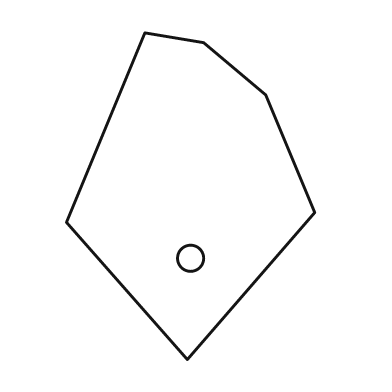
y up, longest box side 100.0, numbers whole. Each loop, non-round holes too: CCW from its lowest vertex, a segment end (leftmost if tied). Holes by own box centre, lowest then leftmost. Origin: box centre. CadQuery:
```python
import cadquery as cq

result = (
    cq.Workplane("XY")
    .moveTo(-1.0, -50.0)
    .lineTo(38.0, -5.0)
    .lineTo(23.0, 31.0)
    .lineTo(4.0, 47.0)
    .lineTo(-14.0, 50.0)
    .lineTo(-38.0, -8.0)
    .close()
    .moveTo(0.0, -19.0)
    .circle(4.0)
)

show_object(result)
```